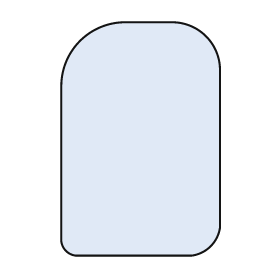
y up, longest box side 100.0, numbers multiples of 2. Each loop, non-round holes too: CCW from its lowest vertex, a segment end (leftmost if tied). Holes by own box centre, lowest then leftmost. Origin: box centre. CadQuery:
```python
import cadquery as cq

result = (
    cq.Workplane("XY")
    .moveTo(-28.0, -50.0)
    .lineTo(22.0, -50.0)
    .threePointArc((30.0, -46.0), (34.0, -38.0))
    .lineTo(34.0, 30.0)
    .threePointArc((28.0, 44.0), (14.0, 50.0))
    .lineTo(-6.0, 50.0)
    .threePointArc((-26.0, 42.0), (-34.0, 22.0))
    .lineTo(-34.0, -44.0)
    .threePointArc((-32.0, -48.0), (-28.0, -50.0))
    .close()
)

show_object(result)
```